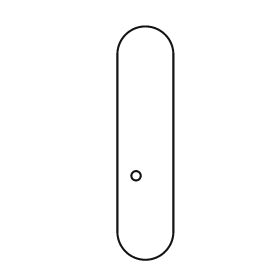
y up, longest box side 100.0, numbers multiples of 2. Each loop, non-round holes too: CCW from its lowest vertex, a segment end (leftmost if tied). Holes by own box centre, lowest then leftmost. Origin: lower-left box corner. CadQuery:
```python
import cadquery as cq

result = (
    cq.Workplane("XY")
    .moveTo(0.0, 12.0)
    .threePointArc((12.0, 0.0), (24.0, 12.0))
    .lineTo(24.0, 88.0)
    .threePointArc((12.0, 100.0), (0.0, 88.0))
    .close()
    .moveTo(8.0, 36.0)
    .circle(2.0)
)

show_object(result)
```